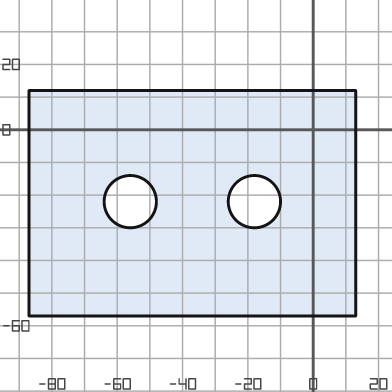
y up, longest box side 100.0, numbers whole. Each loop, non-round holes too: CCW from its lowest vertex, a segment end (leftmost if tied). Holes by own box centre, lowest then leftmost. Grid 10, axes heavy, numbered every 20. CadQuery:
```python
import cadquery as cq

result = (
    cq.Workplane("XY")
    .moveTo(-87.0, -57.0)
    .lineTo(13.0, -57.0)
    .lineTo(13.0, 12.0)
    .lineTo(-87.0, 12.0)
    .close()
    .moveTo(-56.0, -22.0)
    .circle(8.0)
    .moveTo(-18.0, -22.0)
    .circle(8.0)
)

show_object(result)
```